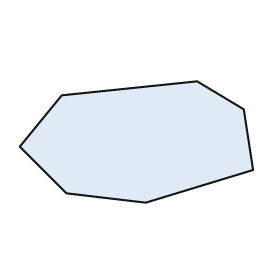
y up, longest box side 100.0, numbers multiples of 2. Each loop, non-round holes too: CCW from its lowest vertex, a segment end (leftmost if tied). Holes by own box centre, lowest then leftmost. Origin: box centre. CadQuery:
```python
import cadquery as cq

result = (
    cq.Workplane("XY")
    .moveTo(4.0, -26.0)
    .lineTo(50.0, -12.0)
    .lineTo(46.0, 14.0)
    .lineTo(26.0, 26.0)
    .lineTo(-32.0, 20.0)
    .lineTo(-50.0, -2.0)
    .lineTo(-30.0, -22.0)
    .close()
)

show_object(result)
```